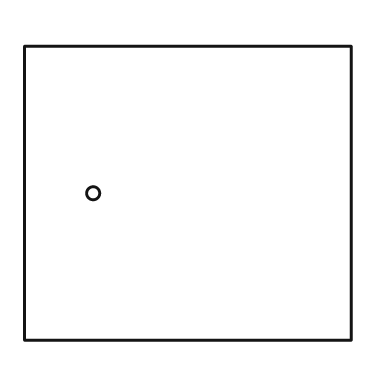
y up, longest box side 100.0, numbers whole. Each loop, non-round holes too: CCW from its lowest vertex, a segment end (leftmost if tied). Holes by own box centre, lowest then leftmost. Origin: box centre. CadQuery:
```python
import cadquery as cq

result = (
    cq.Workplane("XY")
    .moveTo(-50.0, -45.0)
    .lineTo(50.0, -45.0)
    .lineTo(50.0, 45.0)
    .lineTo(-50.0, 45.0)
    .close()
    .moveTo(-29.0, 0.0)
    .circle(2.0)
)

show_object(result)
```